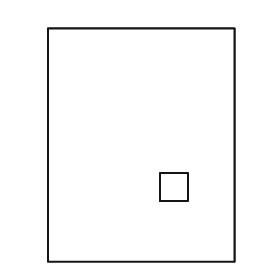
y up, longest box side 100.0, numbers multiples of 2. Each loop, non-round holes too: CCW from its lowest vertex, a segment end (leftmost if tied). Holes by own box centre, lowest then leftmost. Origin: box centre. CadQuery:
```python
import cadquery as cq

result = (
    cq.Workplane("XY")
    .moveTo(-40.0, -50.0)
    .lineTo(40.0, -50.0)
    .lineTo(40.0, 50.0)
    .lineTo(-40.0, 50.0)
    .close()
    .moveTo(8.0, -24.0)
    .lineTo(20.0, -24.0)
    .lineTo(20.0, -12.0)
    .lineTo(8.0, -12.0)
    .close()
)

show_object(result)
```